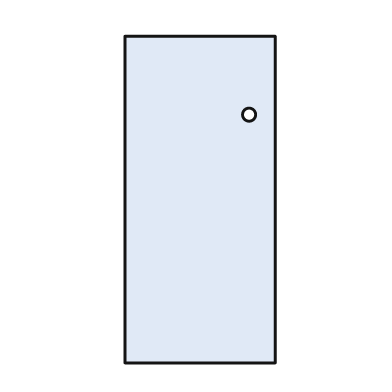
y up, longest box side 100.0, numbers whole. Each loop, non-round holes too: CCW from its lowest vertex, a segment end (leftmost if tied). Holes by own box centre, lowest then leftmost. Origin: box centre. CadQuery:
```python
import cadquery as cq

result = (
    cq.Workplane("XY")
    .moveTo(-23.0, -50.0)
    .lineTo(23.0, -50.0)
    .lineTo(23.0, 50.0)
    .lineTo(-23.0, 50.0)
    .close()
    .moveTo(15.0, 26.0)
    .circle(2.0)
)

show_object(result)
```